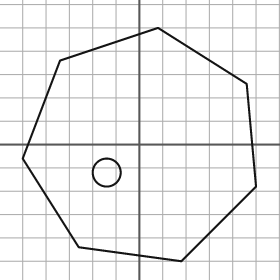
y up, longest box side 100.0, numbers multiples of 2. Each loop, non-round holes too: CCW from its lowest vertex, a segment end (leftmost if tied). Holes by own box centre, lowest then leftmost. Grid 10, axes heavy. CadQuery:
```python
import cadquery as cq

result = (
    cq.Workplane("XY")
    .moveTo(18.0, -50.0)
    .lineTo(50.0, -18.0)
    .lineTo(46.0, 26.0)
    .lineTo(8.0, 50.0)
    .lineTo(-34.0, 36.0)
    .lineTo(-50.0, -6.0)
    .lineTo(-26.0, -44.0)
    .close()
    .moveTo(-14.0, -12.0)
    .circle(6.0)
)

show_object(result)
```